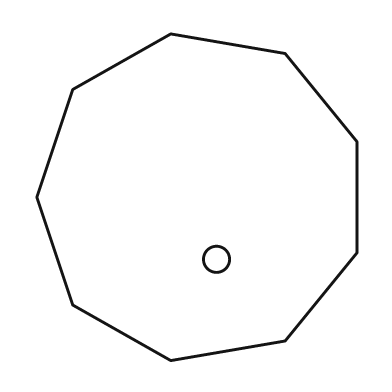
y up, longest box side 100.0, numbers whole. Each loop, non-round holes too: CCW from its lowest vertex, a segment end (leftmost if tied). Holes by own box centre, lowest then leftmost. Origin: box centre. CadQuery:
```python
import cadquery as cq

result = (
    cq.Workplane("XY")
    .moveTo(-8.0, -50.0)
    .lineTo(27.0, -44.0)
    .lineTo(49.0, -17.0)
    .lineTo(49.0, 17.0)
    .lineTo(27.0, 44.0)
    .lineTo(-8.0, 50.0)
    .lineTo(-38.0, 33.0)
    .lineTo(-49.0, 0.0)
    .lineTo(-38.0, -33.0)
    .close()
    .moveTo(6.0, -19.0)
    .circle(4.0)
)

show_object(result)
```